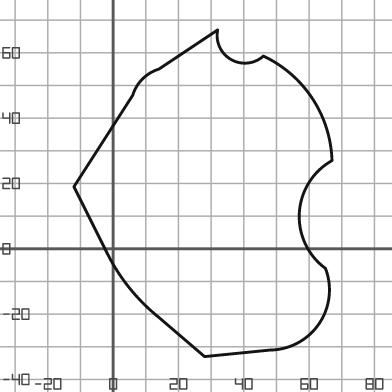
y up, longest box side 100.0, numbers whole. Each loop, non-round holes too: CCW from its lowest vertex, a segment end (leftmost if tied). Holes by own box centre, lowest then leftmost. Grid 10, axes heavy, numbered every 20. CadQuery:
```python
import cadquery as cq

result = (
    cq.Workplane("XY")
    .moveTo(28.0, -33.0)
    .lineTo(48.0, -31.0)
    .threePointArc((63.0, -23.0), (65.0, -6.0))
    .threePointArc((57.0, 11.0), (67.0, 27.0))
    .threePointArc((61.0, 46.0), (46.0, 59.0))
    .threePointArc((36.0, 58.0), (32.0, 67.0))
    .lineTo(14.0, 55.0)
    .threePointArc((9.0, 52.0), (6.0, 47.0))
    .lineTo(-12.0, 19.0)
    .lineTo(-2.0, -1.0)
    .threePointArc((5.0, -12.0), (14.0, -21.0))
    .close()
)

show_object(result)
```